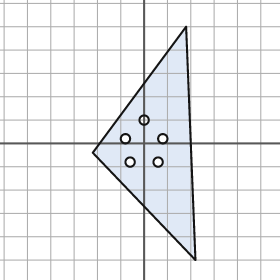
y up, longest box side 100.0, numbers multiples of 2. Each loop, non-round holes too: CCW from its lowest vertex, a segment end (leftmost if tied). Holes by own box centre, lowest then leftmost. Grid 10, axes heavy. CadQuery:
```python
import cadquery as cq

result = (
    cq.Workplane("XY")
    .moveTo(22.0, -50.0)
    .lineTo(18.0, 50.0)
    .lineTo(-22.0, -4.0)
    .close()
    .moveTo(-6.0, -8.0)
    .circle(2.0)
    .moveTo(6.0, -8.0)
    .circle(2.0)
    .moveTo(-8.0, 2.0)
    .circle(2.0)
    .moveTo(8.0, 2.0)
    .circle(2.0)
    .moveTo(0.0, 10.0)
    .circle(2.0)
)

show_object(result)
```